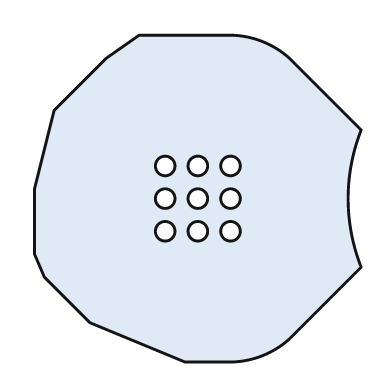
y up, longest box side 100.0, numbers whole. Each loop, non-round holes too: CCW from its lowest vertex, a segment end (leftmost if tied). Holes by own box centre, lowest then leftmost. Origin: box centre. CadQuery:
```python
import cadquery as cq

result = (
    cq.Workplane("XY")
    .moveTo(-4.0, -50.0)
    .lineTo(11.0, -50.0)
    .threePointArc((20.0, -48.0), (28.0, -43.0))
    .lineTo(50.0, -21.0)
    .threePointArc((46.0, 0.0), (50.0, 21.0))
    .lineTo(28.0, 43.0)
    .threePointArc((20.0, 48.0), (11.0, 50.0))
    .lineTo(-18.0, 50.0)
    .lineTo(-28.0, 43.0)
    .lineTo(-44.0, 27.0)
    .lineTo(-50.0, 3.0)
    .lineTo(-50.0, -17.0)
    .lineTo(-47.0, -24.0)
    .lineTo(-33.0, -38.0)
    .close()
    .moveTo(-10.0, -10.0)
    .circle(3.0)
    .moveTo(0.0, -10.0)
    .circle(3.0)
    .moveTo(10.0, -10.0)
    .circle(3.0)
    .moveTo(-10.0, 0.0)
    .circle(3.0)
    .moveTo(0.0, 0.0)
    .circle(3.0)
    .moveTo(10.0, 0.0)
    .circle(3.0)
    .moveTo(-10.0, 10.0)
    .circle(3.0)
    .moveTo(0.0, 10.0)
    .circle(3.0)
    .moveTo(10.0, 10.0)
    .circle(3.0)
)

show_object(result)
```